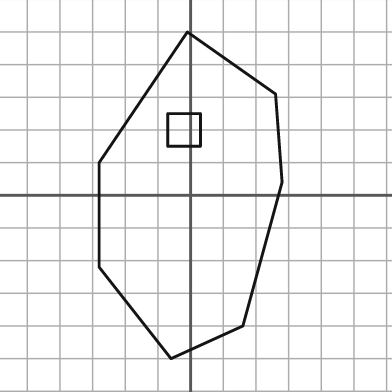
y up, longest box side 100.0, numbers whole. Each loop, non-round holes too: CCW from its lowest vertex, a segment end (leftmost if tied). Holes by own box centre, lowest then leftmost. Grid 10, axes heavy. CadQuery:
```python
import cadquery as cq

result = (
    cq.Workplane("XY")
    .moveTo(-6.0, -50.0)
    .lineTo(16.0, -40.0)
    .lineTo(28.0, 4.0)
    .lineTo(26.0, 31.0)
    .lineTo(-1.0, 50.0)
    .lineTo(-28.0, 10.0)
    .lineTo(-28.0, -22.0)
    .close()
    .moveTo(-7.0, 15.0)
    .lineTo(3.0, 15.0)
    .lineTo(3.0, 25.0)
    .lineTo(-7.0, 25.0)
    .close()
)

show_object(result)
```